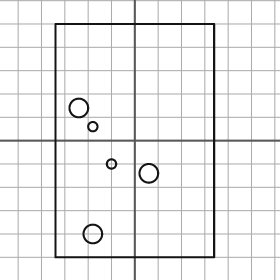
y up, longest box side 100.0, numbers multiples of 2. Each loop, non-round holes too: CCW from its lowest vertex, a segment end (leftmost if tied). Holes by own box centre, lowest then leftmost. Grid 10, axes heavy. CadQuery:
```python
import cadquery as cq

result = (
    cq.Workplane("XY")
    .moveTo(-34.0, -50.0)
    .lineTo(34.0, -50.0)
    .lineTo(34.0, 50.0)
    .lineTo(-34.0, 50.0)
    .close()
    .moveTo(-18.0, -40.0)
    .circle(4.0)
    .moveTo(6.0, -14.0)
    .circle(4.0)
    .moveTo(-10.0, -10.0)
    .circle(2.0)
    .moveTo(-18.0, 6.0)
    .circle(2.0)
    .moveTo(-24.0, 14.0)
    .circle(4.0)
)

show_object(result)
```